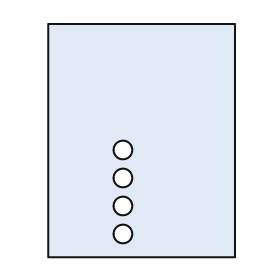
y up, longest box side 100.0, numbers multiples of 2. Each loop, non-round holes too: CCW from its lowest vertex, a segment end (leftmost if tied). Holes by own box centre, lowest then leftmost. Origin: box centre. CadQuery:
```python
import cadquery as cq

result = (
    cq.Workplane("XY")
    .moveTo(-40.0, -50.0)
    .lineTo(40.0, -50.0)
    .lineTo(40.0, 50.0)
    .lineTo(-40.0, 50.0)
    .close()
    .moveTo(-8.0, -40.0)
    .circle(4.0)
    .moveTo(-8.0, -28.0)
    .circle(4.0)
    .moveTo(-8.0, -16.0)
    .circle(4.0)
    .moveTo(-8.0, -4.0)
    .circle(4.0)
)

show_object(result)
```